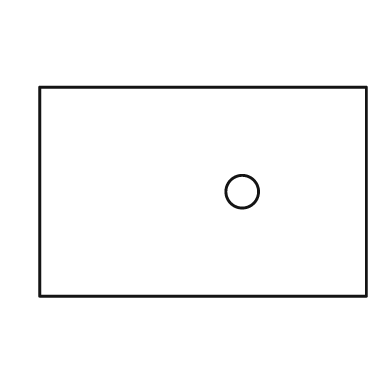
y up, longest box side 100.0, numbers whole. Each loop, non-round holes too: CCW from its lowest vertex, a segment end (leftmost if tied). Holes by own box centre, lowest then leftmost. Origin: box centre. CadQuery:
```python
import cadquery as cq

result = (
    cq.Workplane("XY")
    .moveTo(-50.0, -32.0)
    .lineTo(50.0, -32.0)
    .lineTo(50.0, 32.0)
    .lineTo(-50.0, 32.0)
    .close()
    .moveTo(12.0, 0.0)
    .circle(5.0)
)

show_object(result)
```